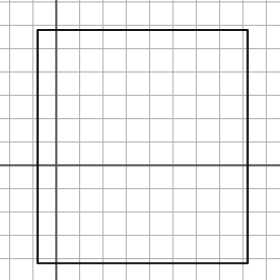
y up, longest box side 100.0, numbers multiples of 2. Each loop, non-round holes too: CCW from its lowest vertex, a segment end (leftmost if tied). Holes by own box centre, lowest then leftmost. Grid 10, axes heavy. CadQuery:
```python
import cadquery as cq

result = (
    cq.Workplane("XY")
    .moveTo(-8.0, -42.0)
    .lineTo(82.0, -42.0)
    .lineTo(82.0, 58.0)
    .lineTo(-8.0, 58.0)
    .close()
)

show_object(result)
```